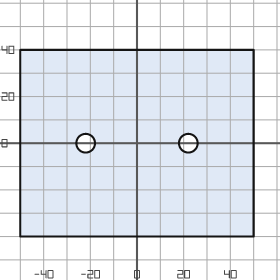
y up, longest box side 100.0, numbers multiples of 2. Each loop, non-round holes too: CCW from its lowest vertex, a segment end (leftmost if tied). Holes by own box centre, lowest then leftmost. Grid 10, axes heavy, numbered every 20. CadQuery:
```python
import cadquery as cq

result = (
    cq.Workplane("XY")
    .moveTo(-50.0, -40.0)
    .lineTo(50.0, -40.0)
    .lineTo(50.0, 40.0)
    .lineTo(-50.0, 40.0)
    .close()
    .moveTo(-22.0, 0.0)
    .circle(4.0)
    .moveTo(22.0, 0.0)
    .circle(4.0)
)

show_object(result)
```